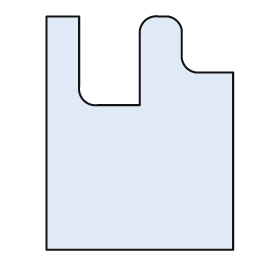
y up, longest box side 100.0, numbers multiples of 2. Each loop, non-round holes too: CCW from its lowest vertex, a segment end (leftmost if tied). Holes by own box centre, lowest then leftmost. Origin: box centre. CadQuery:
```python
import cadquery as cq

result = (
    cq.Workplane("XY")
    .moveTo(-40.0, -50.0)
    .lineTo(40.0, -50.0)
    .lineTo(40.0, 26.0)
    .lineTo(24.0, 26.0)
    .threePointArc((20.0, 28.0), (18.0, 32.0))
    .lineTo(18.0, 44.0)
    .threePointArc((16.0, 48.0), (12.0, 50.0))
    .lineTo(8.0, 50.0)
    .threePointArc((2.0, 48.0), (0.0, 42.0))
    .lineTo(0.0, 12.0)
    .lineTo(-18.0, 12.0)
    .threePointArc((-24.0, 14.0), (-26.0, 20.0))
    .lineTo(-26.0, 50.0)
    .lineTo(-40.0, 50.0)
    .close()
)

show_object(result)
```